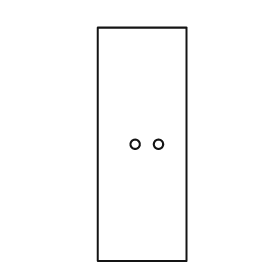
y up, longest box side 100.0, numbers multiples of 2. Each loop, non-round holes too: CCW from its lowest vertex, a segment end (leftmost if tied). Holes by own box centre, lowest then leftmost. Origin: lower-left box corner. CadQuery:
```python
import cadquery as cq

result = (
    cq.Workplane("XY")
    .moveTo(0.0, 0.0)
    .lineTo(38.0, 0.0)
    .lineTo(38.0, 100.0)
    .lineTo(0.0, 100.0)
    .close()
    .moveTo(16.0, 50.0)
    .circle(2.0)
    .moveTo(26.0, 50.0)
    .circle(2.0)
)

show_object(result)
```